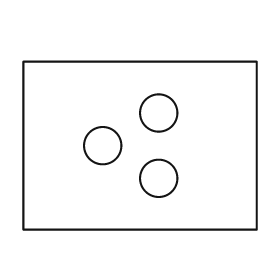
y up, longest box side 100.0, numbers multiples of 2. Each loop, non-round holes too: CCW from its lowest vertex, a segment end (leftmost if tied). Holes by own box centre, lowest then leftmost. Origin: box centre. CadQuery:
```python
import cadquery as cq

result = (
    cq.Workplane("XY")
    .moveTo(-50.0, -36.0)
    .lineTo(50.0, -36.0)
    .lineTo(50.0, 36.0)
    .lineTo(-50.0, 36.0)
    .close()
    .moveTo(8.0, -14.0)
    .circle(8.0)
    .moveTo(-16.0, 0.0)
    .circle(8.0)
    .moveTo(8.0, 14.0)
    .circle(8.0)
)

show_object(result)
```